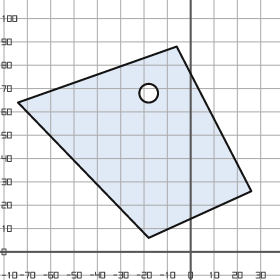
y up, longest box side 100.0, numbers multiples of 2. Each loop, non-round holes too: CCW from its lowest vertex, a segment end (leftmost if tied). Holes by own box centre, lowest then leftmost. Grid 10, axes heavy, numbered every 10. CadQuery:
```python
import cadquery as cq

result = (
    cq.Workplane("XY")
    .moveTo(-18.0, 6.0)
    .lineTo(26.0, 26.0)
    .lineTo(-6.0, 88.0)
    .lineTo(-74.0, 64.0)
    .close()
    .moveTo(-18.0, 68.0)
    .circle(4.0)
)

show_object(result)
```